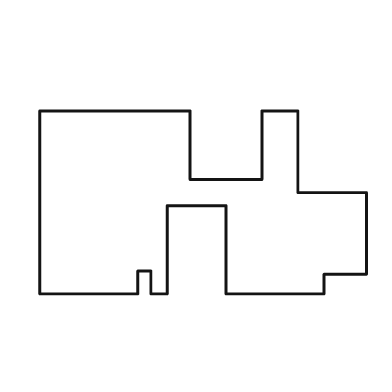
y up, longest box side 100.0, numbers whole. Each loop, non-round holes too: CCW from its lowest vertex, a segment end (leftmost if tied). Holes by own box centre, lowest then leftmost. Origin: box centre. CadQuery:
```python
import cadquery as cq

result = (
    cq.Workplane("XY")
    .moveTo(-50.0, -28.0)
    .lineTo(-20.0, -28.0)
    .lineTo(-20.0, -21.0)
    .lineTo(-16.0, -21.0)
    .lineTo(-16.0, -28.0)
    .lineTo(-11.0, -28.0)
    .lineTo(-11.0, -1.0)
    .lineTo(7.0, -1.0)
    .lineTo(7.0, -28.0)
    .lineTo(37.0, -28.0)
    .lineTo(37.0, -22.0)
    .lineTo(50.0, -22.0)
    .lineTo(50.0, 3.0)
    .lineTo(29.0, 3.0)
    .lineTo(29.0, 28.0)
    .lineTo(18.0, 28.0)
    .lineTo(18.0, 7.0)
    .lineTo(-4.0, 7.0)
    .lineTo(-4.0, 28.0)
    .lineTo(-50.0, 28.0)
    .close()
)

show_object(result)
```